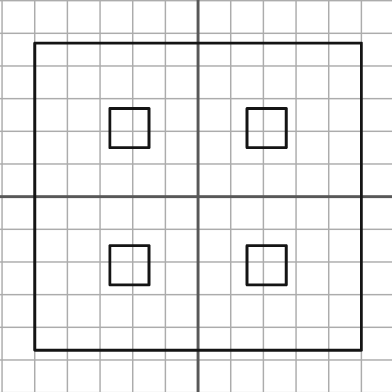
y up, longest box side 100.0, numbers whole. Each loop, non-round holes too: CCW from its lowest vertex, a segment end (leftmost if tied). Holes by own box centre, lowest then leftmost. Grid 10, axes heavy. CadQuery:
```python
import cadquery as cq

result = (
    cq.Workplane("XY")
    .moveTo(-50.0, -47.0)
    .lineTo(50.0, -47.0)
    .lineTo(50.0, 47.0)
    .lineTo(-50.0, 47.0)
    .close()
    .moveTo(-27.0, -27.0)
    .lineTo(-15.0, -27.0)
    .lineTo(-15.0, -15.0)
    .lineTo(-27.0, -15.0)
    .close()
    .moveTo(15.0, -27.0)
    .lineTo(27.0, -27.0)
    .lineTo(27.0, -15.0)
    .lineTo(15.0, -15.0)
    .close()
    .moveTo(-27.0, 15.0)
    .lineTo(-15.0, 15.0)
    .lineTo(-15.0, 27.0)
    .lineTo(-27.0, 27.0)
    .close()
    .moveTo(15.0, 15.0)
    .lineTo(27.0, 15.0)
    .lineTo(27.0, 27.0)
    .lineTo(15.0, 27.0)
    .close()
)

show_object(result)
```